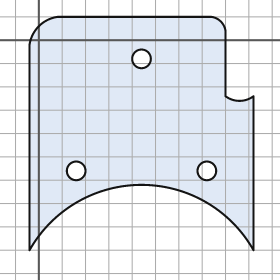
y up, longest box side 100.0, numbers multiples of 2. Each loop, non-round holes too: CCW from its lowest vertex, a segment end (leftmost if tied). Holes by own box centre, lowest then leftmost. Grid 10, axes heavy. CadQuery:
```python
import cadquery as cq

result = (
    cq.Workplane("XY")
    .moveTo(-4.0, -90.0)
    .threePointArc((44.0, -62.0), (92.0, -90.0))
    .lineTo(92.0, -24.0)
    .threePointArc((86.0, -26.0), (80.0, -24.0))
    .lineTo(80.0, 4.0)
    .threePointArc((78.0, 8.0), (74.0, 10.0))
    .lineTo(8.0, 10.0)
    .threePointArc((0.0, 6.0), (-4.0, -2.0))
    .close()
    .moveTo(16.0, -56.0)
    .circle(4.0)
    .moveTo(72.0, -56.0)
    .circle(4.0)
    .moveTo(44.0, -8.0)
    .circle(4.0)
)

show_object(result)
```